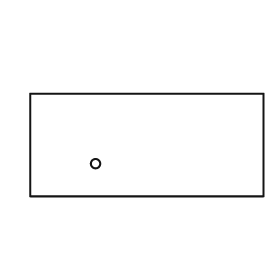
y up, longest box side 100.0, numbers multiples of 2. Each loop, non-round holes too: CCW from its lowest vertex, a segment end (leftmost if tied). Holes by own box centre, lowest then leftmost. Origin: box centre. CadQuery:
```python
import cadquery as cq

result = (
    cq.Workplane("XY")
    .moveTo(-50.0, -22.0)
    .lineTo(50.0, -22.0)
    .lineTo(50.0, 22.0)
    .lineTo(-50.0, 22.0)
    .close()
    .moveTo(-22.0, -8.0)
    .circle(2.0)
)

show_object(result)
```